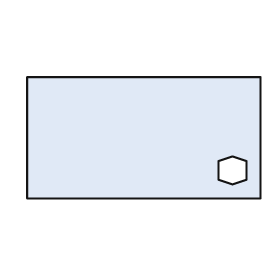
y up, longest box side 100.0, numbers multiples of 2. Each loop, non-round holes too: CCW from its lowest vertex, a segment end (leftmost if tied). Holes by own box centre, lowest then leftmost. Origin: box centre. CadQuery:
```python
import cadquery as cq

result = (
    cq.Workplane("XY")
    .moveTo(-50.0, -26.0)
    .lineTo(50.0, -26.0)
    .lineTo(50.0, 26.0)
    .lineTo(-50.0, 26.0)
    .close()
    .moveTo(38.0, -20.0)
    .lineTo(44.0, -18.0)
    .lineTo(44.0, -10.0)
    .lineTo(38.0, -8.0)
    .lineTo(32.0, -10.0)
    .lineTo(32.0, -18.0)
    .close()
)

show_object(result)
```